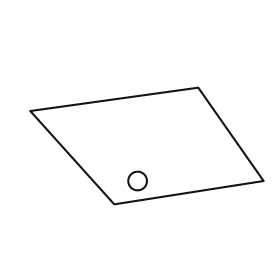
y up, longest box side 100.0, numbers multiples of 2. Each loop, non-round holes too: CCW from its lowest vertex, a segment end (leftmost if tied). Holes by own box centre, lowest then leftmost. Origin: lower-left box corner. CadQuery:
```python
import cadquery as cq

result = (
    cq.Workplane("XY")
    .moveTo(36.0, 0.0)
    .lineTo(100.0, 10.0)
    .lineTo(72.0, 50.0)
    .lineTo(0.0, 40.0)
    .close()
    .moveTo(46.0, 10.0)
    .circle(4.0)
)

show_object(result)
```